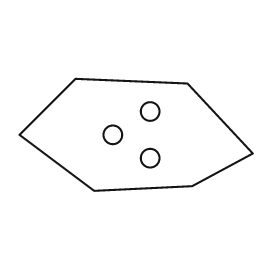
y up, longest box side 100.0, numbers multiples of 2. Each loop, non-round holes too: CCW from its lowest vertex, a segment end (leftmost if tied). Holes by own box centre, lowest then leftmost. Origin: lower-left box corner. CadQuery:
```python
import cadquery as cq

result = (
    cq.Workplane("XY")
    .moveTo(32.0, 0.0)
    .lineTo(74.0, 2.0)
    .lineTo(100.0, 16.0)
    .lineTo(72.0, 46.0)
    .lineTo(24.0, 48.0)
    .lineTo(0.0, 24.0)
    .close()
    .moveTo(56.0, 14.0)
    .circle(4.0)
    .moveTo(40.0, 24.0)
    .circle(4.0)
    .moveTo(56.0, 34.0)
    .circle(4.0)
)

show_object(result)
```